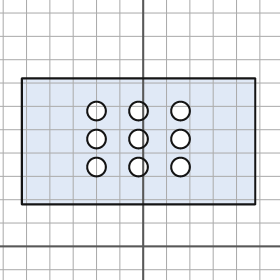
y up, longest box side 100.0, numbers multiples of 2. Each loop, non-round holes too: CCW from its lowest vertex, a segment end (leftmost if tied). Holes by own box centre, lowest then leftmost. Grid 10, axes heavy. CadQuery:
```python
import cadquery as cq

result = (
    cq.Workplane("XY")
    .moveTo(-52.0, 18.0)
    .lineTo(48.0, 18.0)
    .lineTo(48.0, 72.0)
    .lineTo(-52.0, 72.0)
    .close()
    .moveTo(-20.0, 34.0)
    .circle(4.0)
    .moveTo(-2.0, 34.0)
    .circle(4.0)
    .moveTo(16.0, 34.0)
    .circle(4.0)
    .moveTo(-20.0, 46.0)
    .circle(4.0)
    .moveTo(-2.0, 46.0)
    .circle(4.0)
    .moveTo(16.0, 46.0)
    .circle(4.0)
    .moveTo(-20.0, 58.0)
    .circle(4.0)
    .moveTo(-2.0, 58.0)
    .circle(4.0)
    .moveTo(16.0, 58.0)
    .circle(4.0)
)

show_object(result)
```